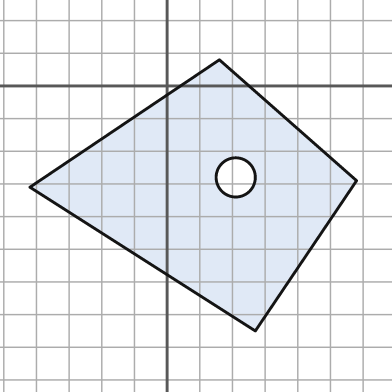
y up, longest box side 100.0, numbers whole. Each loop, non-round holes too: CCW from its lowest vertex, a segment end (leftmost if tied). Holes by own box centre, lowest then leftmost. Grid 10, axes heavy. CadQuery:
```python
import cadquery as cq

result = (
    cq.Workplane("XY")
    .moveTo(27.0, -75.0)
    .lineTo(58.0, -29.0)
    .lineTo(16.0, 8.0)
    .lineTo(-42.0, -31.0)
    .close()
    .moveTo(21.0, -28.0)
    .circle(6.0)
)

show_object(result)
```